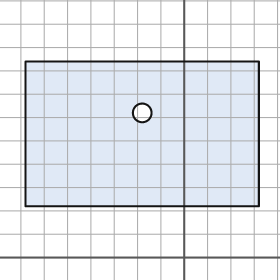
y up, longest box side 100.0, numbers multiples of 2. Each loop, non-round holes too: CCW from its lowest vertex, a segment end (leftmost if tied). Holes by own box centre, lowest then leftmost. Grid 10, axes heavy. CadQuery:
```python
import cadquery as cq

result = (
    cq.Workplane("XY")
    .moveTo(-68.0, 22.0)
    .lineTo(32.0, 22.0)
    .lineTo(32.0, 84.0)
    .lineTo(-68.0, 84.0)
    .close()
    .moveTo(-18.0, 62.0)
    .circle(4.0)
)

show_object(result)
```